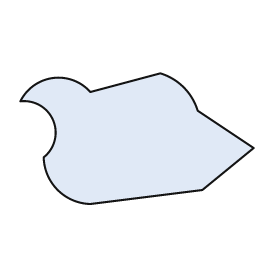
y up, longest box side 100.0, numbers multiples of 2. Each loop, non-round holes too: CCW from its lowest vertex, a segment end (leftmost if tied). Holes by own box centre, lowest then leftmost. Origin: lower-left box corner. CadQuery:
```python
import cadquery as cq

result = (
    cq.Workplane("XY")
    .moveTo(30.0, 0.0)
    .lineTo(78.0, 6.0)
    .lineTo(100.0, 24.0)
    .lineTo(76.0, 40.0)
    .threePointArc((70.0, 50.0), (60.0, 56.0))
    .lineTo(30.0, 48.0)
    .threePointArc((14.0, 54.0), (0.0, 44.0))
    .threePointArc((14.0, 36.0), (10.0, 20.0))
    .threePointArc((16.0, 6.0), (30.0, 0.0))
    .close()
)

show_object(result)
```